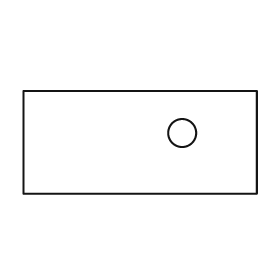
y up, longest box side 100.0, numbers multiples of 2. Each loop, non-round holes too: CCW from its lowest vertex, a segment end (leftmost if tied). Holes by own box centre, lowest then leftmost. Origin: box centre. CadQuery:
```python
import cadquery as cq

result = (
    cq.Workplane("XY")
    .moveTo(-50.0, -22.0)
    .lineTo(50.0, -22.0)
    .lineTo(50.0, 22.0)
    .lineTo(-50.0, 22.0)
    .close()
    .moveTo(18.0, 4.0)
    .circle(6.0)
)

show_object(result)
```